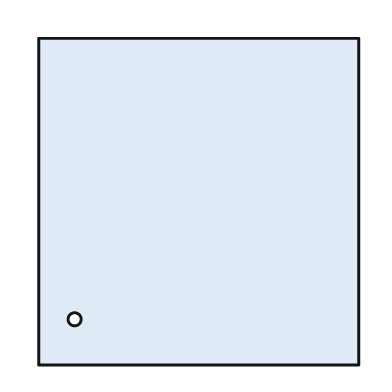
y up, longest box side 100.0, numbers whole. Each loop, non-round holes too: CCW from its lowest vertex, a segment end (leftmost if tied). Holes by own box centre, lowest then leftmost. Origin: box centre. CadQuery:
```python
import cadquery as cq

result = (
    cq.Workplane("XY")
    .moveTo(-49.0, -50.0)
    .lineTo(49.0, -50.0)
    .lineTo(49.0, 50.0)
    .lineTo(-49.0, 50.0)
    .close()
    .moveTo(-38.0, -36.0)
    .circle(2.0)
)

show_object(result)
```